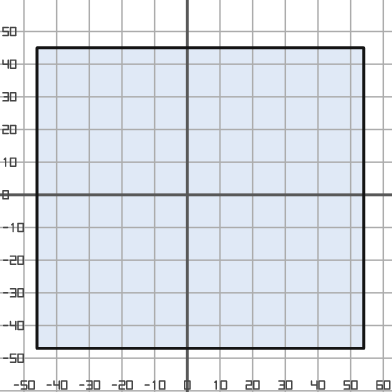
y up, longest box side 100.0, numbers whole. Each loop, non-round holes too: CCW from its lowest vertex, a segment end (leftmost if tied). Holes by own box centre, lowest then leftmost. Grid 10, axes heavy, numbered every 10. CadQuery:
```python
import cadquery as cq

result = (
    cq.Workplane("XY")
    .moveTo(-46.0, -47.0)
    .lineTo(54.0, -47.0)
    .lineTo(54.0, 45.0)
    .lineTo(-46.0, 45.0)
    .close()
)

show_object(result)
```